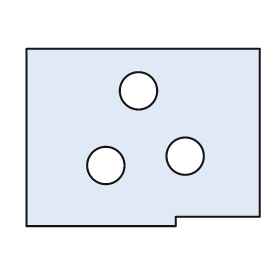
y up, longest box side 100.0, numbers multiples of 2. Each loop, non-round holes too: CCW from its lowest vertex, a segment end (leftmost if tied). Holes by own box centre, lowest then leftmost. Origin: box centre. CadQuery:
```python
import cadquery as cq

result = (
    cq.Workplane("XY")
    .moveTo(-50.0, -38.0)
    .lineTo(14.0, -38.0)
    .lineTo(14.0, -34.0)
    .lineTo(50.0, -34.0)
    .lineTo(50.0, 38.0)
    .lineTo(-50.0, 38.0)
    .close()
    .moveTo(-16.0, -12.0)
    .circle(8.0)
    .moveTo(18.0, -8.0)
    .circle(8.0)
    .moveTo(-2.0, 20.0)
    .circle(8.0)
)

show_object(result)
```